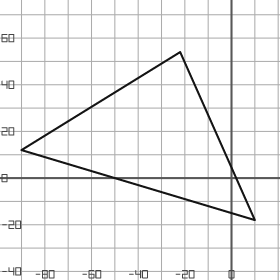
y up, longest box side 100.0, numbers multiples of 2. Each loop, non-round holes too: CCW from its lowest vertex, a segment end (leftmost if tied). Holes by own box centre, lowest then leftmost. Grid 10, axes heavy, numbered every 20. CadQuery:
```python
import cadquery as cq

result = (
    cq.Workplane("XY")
    .moveTo(10.0, -18.0)
    .lineTo(-22.0, 54.0)
    .lineTo(-90.0, 12.0)
    .close()
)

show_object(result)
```